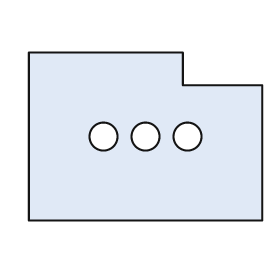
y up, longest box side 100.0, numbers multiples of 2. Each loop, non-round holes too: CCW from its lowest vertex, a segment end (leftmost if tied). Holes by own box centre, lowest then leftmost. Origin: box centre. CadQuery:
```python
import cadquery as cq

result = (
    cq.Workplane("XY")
    .moveTo(-50.0, -36.0)
    .lineTo(50.0, -36.0)
    .lineTo(50.0, 22.0)
    .lineTo(16.0, 22.0)
    .lineTo(16.0, 36.0)
    .lineTo(-50.0, 36.0)
    .close()
    .moveTo(-18.0, 0.0)
    .circle(6.0)
    .moveTo(0.0, 0.0)
    .circle(6.0)
    .moveTo(18.0, 0.0)
    .circle(6.0)
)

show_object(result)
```